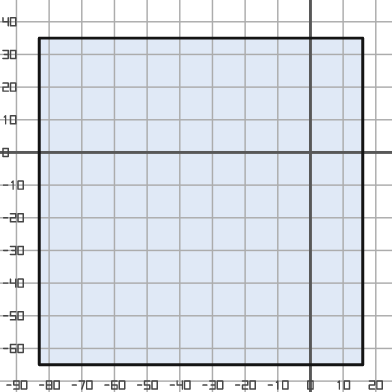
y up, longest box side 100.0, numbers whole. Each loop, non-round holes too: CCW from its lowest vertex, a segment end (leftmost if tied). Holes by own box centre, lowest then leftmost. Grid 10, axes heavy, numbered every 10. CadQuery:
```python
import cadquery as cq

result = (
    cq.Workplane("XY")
    .moveTo(-83.0, -65.0)
    .lineTo(16.0, -65.0)
    .lineTo(16.0, 35.0)
    .lineTo(-83.0, 35.0)
    .close()
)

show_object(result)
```